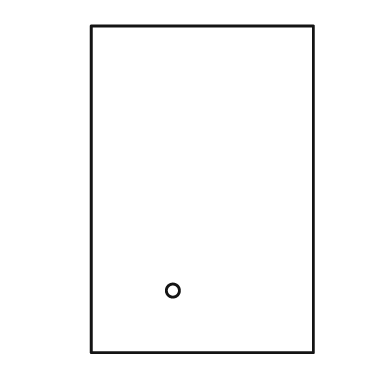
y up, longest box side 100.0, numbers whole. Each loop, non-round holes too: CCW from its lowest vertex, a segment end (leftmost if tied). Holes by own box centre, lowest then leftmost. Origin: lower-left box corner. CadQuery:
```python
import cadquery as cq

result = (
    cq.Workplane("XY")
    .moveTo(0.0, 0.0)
    .lineTo(68.0, 0.0)
    .lineTo(68.0, 100.0)
    .lineTo(0.0, 100.0)
    .close()
    .moveTo(25.0, 19.0)
    .circle(2.0)
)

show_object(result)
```